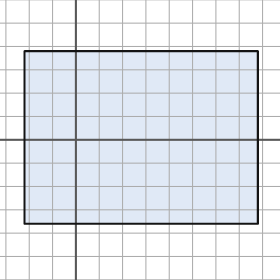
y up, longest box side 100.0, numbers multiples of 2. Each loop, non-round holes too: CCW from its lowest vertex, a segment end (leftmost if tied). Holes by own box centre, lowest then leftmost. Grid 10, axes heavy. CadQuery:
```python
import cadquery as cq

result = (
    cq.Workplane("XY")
    .moveTo(-22.0, -36.0)
    .lineTo(78.0, -36.0)
    .lineTo(78.0, 38.0)
    .lineTo(-22.0, 38.0)
    .close()
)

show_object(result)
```